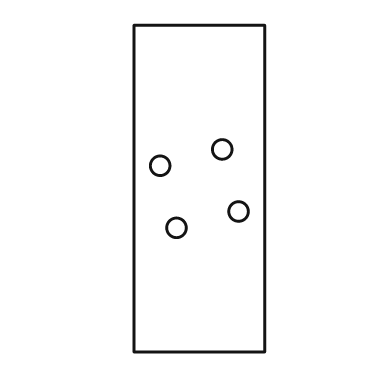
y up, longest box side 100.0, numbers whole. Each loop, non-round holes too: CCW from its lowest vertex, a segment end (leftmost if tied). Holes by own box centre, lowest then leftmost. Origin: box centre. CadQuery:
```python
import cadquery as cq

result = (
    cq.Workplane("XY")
    .moveTo(-20.0, -50.0)
    .lineTo(20.0, -50.0)
    .lineTo(20.0, 50.0)
    .lineTo(-20.0, 50.0)
    .close()
    .moveTo(-7.0, -12.0)
    .circle(3.0)
    .moveTo(12.0, -7.0)
    .circle(3.0)
    .moveTo(-12.0, 7.0)
    .circle(3.0)
    .moveTo(7.0, 12.0)
    .circle(3.0)
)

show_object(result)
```